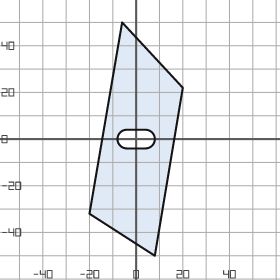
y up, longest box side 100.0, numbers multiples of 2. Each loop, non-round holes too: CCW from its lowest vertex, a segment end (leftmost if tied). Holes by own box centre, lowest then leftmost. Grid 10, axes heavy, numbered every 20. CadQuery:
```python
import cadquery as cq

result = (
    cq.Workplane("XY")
    .moveTo(8.0, -50.0)
    .lineTo(20.0, 22.0)
    .lineTo(-6.0, 50.0)
    .lineTo(-20.0, -32.0)
    .close()
    .moveTo(-4.0, -4.0)
    .lineTo(4.0, -4.0)
    .threePointArc((8.0, 0.0), (4.0, 4.0))
    .lineTo(-4.0, 4.0)
    .threePointArc((-8.0, 0.0), (-4.0, -4.0))
    .close()
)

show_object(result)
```